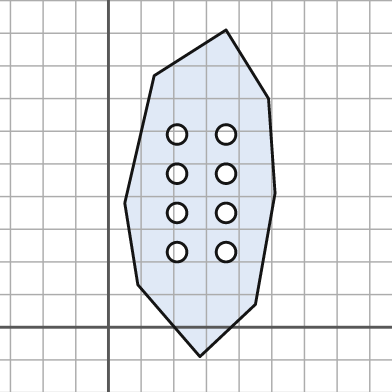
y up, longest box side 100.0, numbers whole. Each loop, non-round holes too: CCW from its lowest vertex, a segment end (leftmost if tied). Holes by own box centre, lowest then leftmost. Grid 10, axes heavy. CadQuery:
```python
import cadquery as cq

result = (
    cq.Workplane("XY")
    .moveTo(28.0, -9.0)
    .lineTo(45.0, 7.0)
    .lineTo(51.0, 41.0)
    .lineTo(49.0, 70.0)
    .lineTo(36.0, 91.0)
    .lineTo(14.0, 77.0)
    .lineTo(5.0, 38.0)
    .lineTo(9.0, 13.0)
    .close()
    .moveTo(21.0, 23.0)
    .circle(3.0)
    .moveTo(36.0, 23.0)
    .circle(3.0)
    .moveTo(21.0, 35.0)
    .circle(3.0)
    .moveTo(36.0, 35.0)
    .circle(3.0)
    .moveTo(21.0, 47.0)
    .circle(3.0)
    .moveTo(36.0, 47.0)
    .circle(3.0)
    .moveTo(21.0, 59.0)
    .circle(3.0)
    .moveTo(36.0, 59.0)
    .circle(3.0)
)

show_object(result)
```